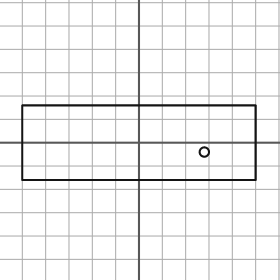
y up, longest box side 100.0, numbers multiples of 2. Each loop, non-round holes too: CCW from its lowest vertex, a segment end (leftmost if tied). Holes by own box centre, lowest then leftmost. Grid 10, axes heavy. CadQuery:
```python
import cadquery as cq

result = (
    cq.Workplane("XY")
    .moveTo(-50.0, -16.0)
    .lineTo(50.0, -16.0)
    .lineTo(50.0, 16.0)
    .lineTo(-50.0, 16.0)
    .close()
    .moveTo(28.0, -4.0)
    .circle(2.0)
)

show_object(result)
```